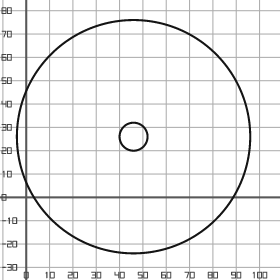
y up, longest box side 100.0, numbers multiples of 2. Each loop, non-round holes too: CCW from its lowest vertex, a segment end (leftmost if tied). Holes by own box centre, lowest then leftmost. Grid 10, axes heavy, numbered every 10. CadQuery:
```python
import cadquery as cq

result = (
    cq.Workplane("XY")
    .moveTo(46.0, 26.0)
    .circle(50.0)
    .moveTo(46.0, 26.0)
    .circle(6.0)
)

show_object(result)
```